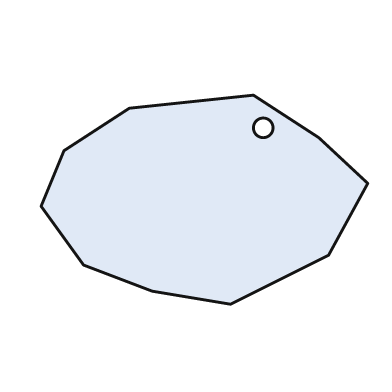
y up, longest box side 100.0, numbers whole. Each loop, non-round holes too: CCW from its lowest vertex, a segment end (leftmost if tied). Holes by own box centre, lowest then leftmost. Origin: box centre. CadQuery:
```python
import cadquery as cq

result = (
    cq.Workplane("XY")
    .moveTo(8.0, -32.0)
    .lineTo(38.0, -17.0)
    .lineTo(50.0, 5.0)
    .lineTo(35.0, 19.0)
    .lineTo(15.0, 32.0)
    .lineTo(-23.0, 28.0)
    .lineTo(-43.0, 15.0)
    .lineTo(-50.0, -2.0)
    .lineTo(-37.0, -20.0)
    .lineTo(-16.0, -28.0)
    .close()
    .moveTo(18.0, 22.0)
    .circle(3.0)
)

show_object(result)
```